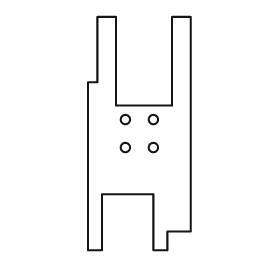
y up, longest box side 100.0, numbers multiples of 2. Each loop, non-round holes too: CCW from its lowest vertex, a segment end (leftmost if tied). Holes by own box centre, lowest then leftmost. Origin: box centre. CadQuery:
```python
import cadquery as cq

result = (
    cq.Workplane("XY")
    .moveTo(-22.0, -50.0)
    .lineTo(-16.0, -50.0)
    .lineTo(-16.0, -26.0)
    .lineTo(6.0, -26.0)
    .lineTo(6.0, -50.0)
    .lineTo(12.0, -50.0)
    .lineTo(12.0, -42.0)
    .lineTo(22.0, -42.0)
    .lineTo(22.0, 50.0)
    .lineTo(14.0, 50.0)
    .lineTo(14.0, 12.0)
    .lineTo(-10.0, 12.0)
    .lineTo(-10.0, 50.0)
    .lineTo(-18.0, 50.0)
    .lineTo(-18.0, 22.0)
    .lineTo(-22.0, 22.0)
    .close()
    .moveTo(-6.0, -6.0)
    .circle(2.0)
    .moveTo(6.0, -6.0)
    .circle(2.0)
    .moveTo(-6.0, 6.0)
    .circle(2.0)
    .moveTo(6.0, 6.0)
    .circle(2.0)
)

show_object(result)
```